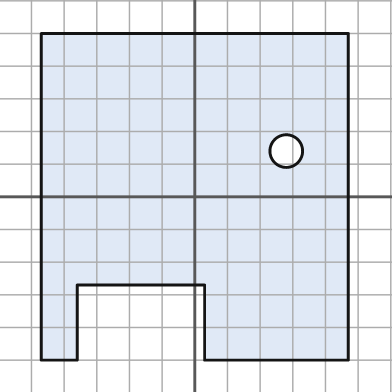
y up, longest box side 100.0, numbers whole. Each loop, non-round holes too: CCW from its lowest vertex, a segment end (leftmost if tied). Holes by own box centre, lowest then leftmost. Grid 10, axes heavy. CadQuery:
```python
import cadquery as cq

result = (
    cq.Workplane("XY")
    .moveTo(-47.0, -50.0)
    .lineTo(-36.0, -50.0)
    .lineTo(-36.0, -27.0)
    .lineTo(3.0, -27.0)
    .lineTo(3.0, -50.0)
    .lineTo(47.0, -50.0)
    .lineTo(47.0, 50.0)
    .lineTo(-47.0, 50.0)
    .close()
    .moveTo(28.0, 14.0)
    .circle(5.0)
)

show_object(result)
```